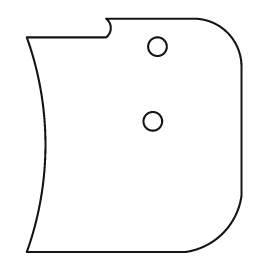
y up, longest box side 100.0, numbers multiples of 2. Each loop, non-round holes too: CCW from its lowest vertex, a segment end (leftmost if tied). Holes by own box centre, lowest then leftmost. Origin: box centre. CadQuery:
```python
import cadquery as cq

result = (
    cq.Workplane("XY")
    .moveTo(-46.0, -50.0)
    .lineTo(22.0, -50.0)
    .threePointArc((38.0, -42.0), (46.0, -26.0))
    .lineTo(46.0, 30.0)
    .threePointArc((40.0, 44.0), (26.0, 50.0))
    .lineTo(-12.0, 50.0)
    .threePointArc((-10.0, 46.0), (-12.0, 42.0))
    .lineTo(-46.0, 42.0)
    .threePointArc((-38.0, -4.0), (-46.0, -50.0))
    .close()
    .moveTo(8.0, 6.0)
    .circle(4.0)
    .moveTo(10.0, 38.0)
    .circle(4.0)
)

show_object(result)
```